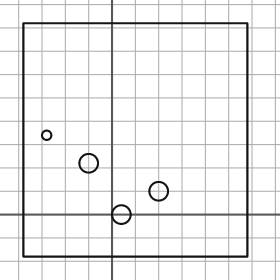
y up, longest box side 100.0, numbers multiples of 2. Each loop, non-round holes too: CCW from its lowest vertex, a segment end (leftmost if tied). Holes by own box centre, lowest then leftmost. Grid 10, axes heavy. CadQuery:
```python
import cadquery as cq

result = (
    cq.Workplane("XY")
    .moveTo(-38.0, -18.0)
    .lineTo(58.0, -18.0)
    .lineTo(58.0, 82.0)
    .lineTo(-38.0, 82.0)
    .close()
    .moveTo(4.0, 0.0)
    .circle(4.0)
    .moveTo(20.0, 10.0)
    .circle(4.0)
    .moveTo(-10.0, 22.0)
    .circle(4.0)
    .moveTo(-28.0, 34.0)
    .circle(2.0)
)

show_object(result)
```